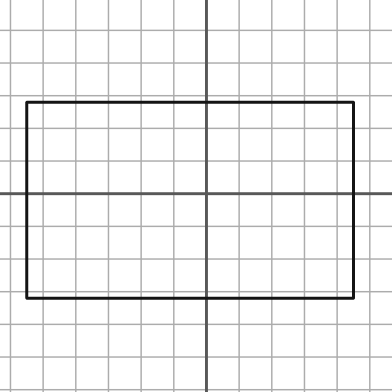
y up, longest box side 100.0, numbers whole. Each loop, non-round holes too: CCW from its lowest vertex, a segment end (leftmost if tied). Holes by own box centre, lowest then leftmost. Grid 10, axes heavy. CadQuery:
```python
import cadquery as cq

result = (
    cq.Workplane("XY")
    .moveTo(-55.0, -32.0)
    .lineTo(45.0, -32.0)
    .lineTo(45.0, 28.0)
    .lineTo(-55.0, 28.0)
    .close()
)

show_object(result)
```